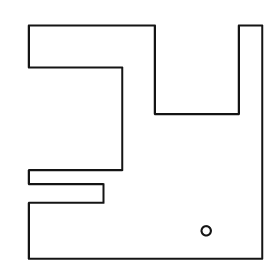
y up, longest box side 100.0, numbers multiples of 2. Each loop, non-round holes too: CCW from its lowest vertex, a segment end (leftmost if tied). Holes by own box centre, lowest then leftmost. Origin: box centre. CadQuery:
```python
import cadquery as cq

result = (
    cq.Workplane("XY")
    .moveTo(-50.0, -50.0)
    .lineTo(50.0, -50.0)
    .lineTo(50.0, 50.0)
    .lineTo(40.0, 50.0)
    .lineTo(40.0, 12.0)
    .lineTo(4.0, 12.0)
    .lineTo(4.0, 50.0)
    .lineTo(-50.0, 50.0)
    .lineTo(-50.0, 32.0)
    .lineTo(-10.0, 32.0)
    .lineTo(-10.0, -12.0)
    .lineTo(-50.0, -12.0)
    .lineTo(-50.0, -18.0)
    .lineTo(-18.0, -18.0)
    .lineTo(-18.0, -26.0)
    .lineTo(-50.0, -26.0)
    .close()
    .moveTo(26.0, -38.0)
    .circle(2.0)
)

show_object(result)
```